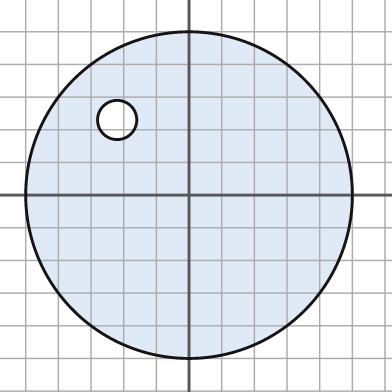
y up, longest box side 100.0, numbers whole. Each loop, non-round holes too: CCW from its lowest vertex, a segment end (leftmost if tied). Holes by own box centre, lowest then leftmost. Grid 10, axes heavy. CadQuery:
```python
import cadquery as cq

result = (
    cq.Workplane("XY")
    .moveTo(0.0, 0.0)
    .circle(50.0)
    .moveTo(-22.0, 23.0)
    .circle(6.0)
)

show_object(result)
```